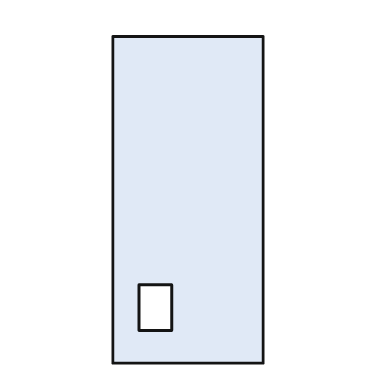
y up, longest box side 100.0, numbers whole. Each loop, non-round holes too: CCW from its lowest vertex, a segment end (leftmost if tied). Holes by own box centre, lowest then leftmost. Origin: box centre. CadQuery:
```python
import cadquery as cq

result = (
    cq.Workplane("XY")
    .moveTo(-23.0, -50.0)
    .lineTo(23.0, -50.0)
    .lineTo(23.0, 50.0)
    .lineTo(-23.0, 50.0)
    .close()
    .moveTo(-15.0, -40.0)
    .lineTo(-5.0, -40.0)
    .lineTo(-5.0, -26.0)
    .lineTo(-15.0, -26.0)
    .close()
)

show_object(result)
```